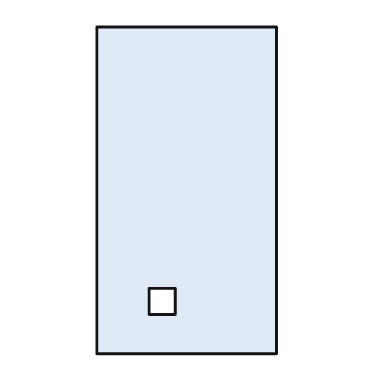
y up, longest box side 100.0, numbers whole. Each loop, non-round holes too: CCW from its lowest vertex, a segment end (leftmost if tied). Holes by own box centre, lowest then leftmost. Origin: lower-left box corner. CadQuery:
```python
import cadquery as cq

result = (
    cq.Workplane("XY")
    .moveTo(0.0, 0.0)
    .lineTo(55.0, 0.0)
    .lineTo(55.0, 100.0)
    .lineTo(0.0, 100.0)
    .close()
    .moveTo(16.0, 12.0)
    .lineTo(24.0, 12.0)
    .lineTo(24.0, 20.0)
    .lineTo(16.0, 20.0)
    .close()
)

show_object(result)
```